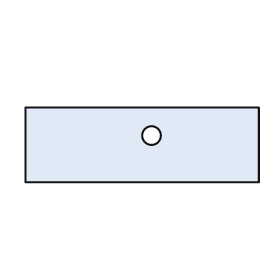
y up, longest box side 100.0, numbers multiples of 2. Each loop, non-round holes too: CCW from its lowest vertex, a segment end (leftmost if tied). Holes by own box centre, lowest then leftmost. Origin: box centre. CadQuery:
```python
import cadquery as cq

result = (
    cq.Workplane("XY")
    .moveTo(-50.0, -16.0)
    .lineTo(50.0, -16.0)
    .lineTo(50.0, 16.0)
    .lineTo(-50.0, 16.0)
    .close()
    .moveTo(4.0, 4.0)
    .circle(4.0)
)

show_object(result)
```